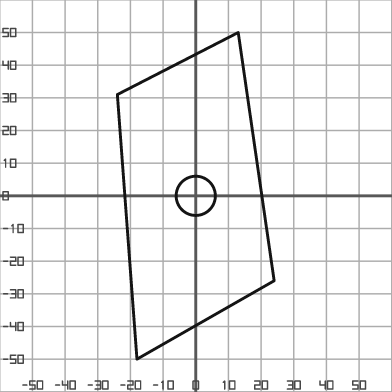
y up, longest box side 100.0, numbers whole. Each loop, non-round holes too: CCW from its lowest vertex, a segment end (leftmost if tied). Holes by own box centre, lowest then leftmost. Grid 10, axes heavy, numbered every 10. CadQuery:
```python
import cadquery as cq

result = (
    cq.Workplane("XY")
    .moveTo(-18.0, -50.0)
    .lineTo(24.0, -26.0)
    .lineTo(13.0, 50.0)
    .lineTo(-24.0, 31.0)
    .close()
    .moveTo(0.0, 0.0)
    .circle(6.0)
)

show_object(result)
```